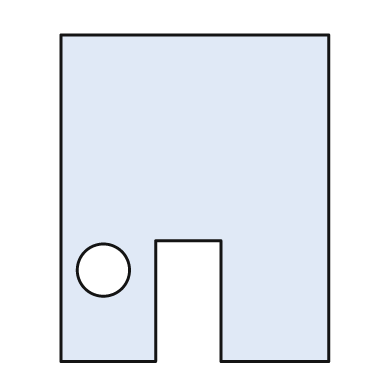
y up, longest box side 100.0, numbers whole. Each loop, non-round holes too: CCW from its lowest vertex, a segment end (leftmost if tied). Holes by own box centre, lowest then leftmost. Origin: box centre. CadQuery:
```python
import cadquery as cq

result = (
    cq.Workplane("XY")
    .moveTo(-41.0, -50.0)
    .lineTo(-12.0, -50.0)
    .lineTo(-12.0, -13.0)
    .lineTo(8.0, -13.0)
    .lineTo(8.0, -50.0)
    .lineTo(41.0, -50.0)
    .lineTo(41.0, 50.0)
    .lineTo(-41.0, 50.0)
    .close()
    .moveTo(-28.0, -22.0)
    .circle(8.0)
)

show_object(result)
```